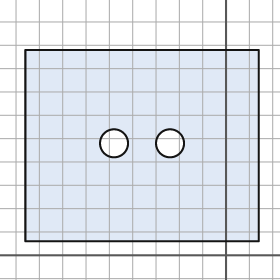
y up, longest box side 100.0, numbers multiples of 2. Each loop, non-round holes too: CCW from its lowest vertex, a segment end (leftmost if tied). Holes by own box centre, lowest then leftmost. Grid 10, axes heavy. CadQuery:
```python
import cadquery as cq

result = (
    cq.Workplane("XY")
    .moveTo(-86.0, 6.0)
    .lineTo(14.0, 6.0)
    .lineTo(14.0, 88.0)
    .lineTo(-86.0, 88.0)
    .close()
    .moveTo(-48.0, 48.0)
    .circle(6.0)
    .moveTo(-24.0, 48.0)
    .circle(6.0)
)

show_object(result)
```